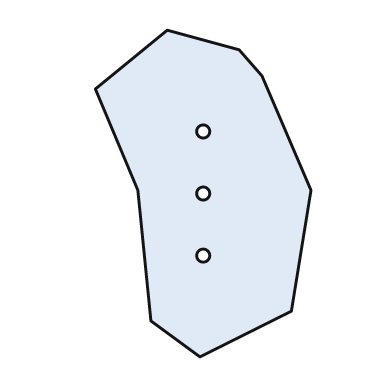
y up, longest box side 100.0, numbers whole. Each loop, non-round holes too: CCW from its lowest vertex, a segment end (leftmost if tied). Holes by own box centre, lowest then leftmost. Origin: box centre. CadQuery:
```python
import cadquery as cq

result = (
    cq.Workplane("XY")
    .moveTo(-1.0, -50.0)
    .lineTo(27.0, -36.0)
    .lineTo(33.0, 1.0)
    .lineTo(18.0, 36.0)
    .lineTo(11.0, 44.0)
    .lineTo(-11.0, 50.0)
    .lineTo(-33.0, 32.0)
    .lineTo(-20.0, 1.0)
    .lineTo(-16.0, -39.0)
    .close()
    .moveTo(0.0, -19.0)
    .circle(2.0)
    .moveTo(0.0, 0.0)
    .circle(2.0)
    .moveTo(0.0, 19.0)
    .circle(2.0)
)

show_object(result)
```